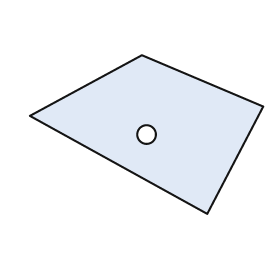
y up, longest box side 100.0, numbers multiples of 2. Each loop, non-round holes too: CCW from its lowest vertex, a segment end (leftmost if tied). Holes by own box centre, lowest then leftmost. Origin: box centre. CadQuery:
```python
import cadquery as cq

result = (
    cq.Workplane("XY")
    .moveTo(26.0, -34.0)
    .lineTo(50.0, 12.0)
    .lineTo(-2.0, 34.0)
    .lineTo(-50.0, 8.0)
    .close()
    .moveTo(0.0, 0.0)
    .circle(4.0)
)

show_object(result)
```